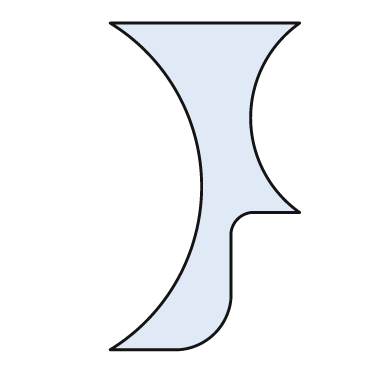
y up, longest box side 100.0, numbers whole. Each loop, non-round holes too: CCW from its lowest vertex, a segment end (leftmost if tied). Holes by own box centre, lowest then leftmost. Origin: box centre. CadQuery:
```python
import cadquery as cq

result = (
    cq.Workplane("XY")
    .moveTo(-29.0, -50.0)
    .lineTo(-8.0, -50.0)
    .threePointArc((3.0, -45.0), (8.0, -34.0))
    .lineTo(8.0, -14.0)
    .threePointArc((10.0, -10.0), (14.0, -8.0))
    .lineTo(29.0, -8.0)
    .threePointArc((14.0, 21.0), (29.0, 50.0))
    .lineTo(-29.0, 50.0)
    .threePointArc((-1.0, 0.0), (-29.0, -50.0))
    .close()
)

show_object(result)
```